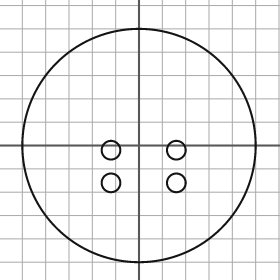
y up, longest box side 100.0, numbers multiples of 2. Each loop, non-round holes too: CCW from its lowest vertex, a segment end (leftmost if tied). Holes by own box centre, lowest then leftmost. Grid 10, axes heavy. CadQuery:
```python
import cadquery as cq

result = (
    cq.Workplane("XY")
    .moveTo(0.0, 0.0)
    .circle(50.0)
    .moveTo(-12.0, -16.0)
    .circle(4.0)
    .moveTo(16.0, -16.0)
    .circle(4.0)
    .moveTo(-12.0, -2.0)
    .circle(4.0)
    .moveTo(16.0, -2.0)
    .circle(4.0)
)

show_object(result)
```